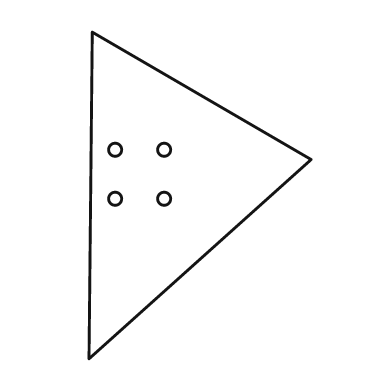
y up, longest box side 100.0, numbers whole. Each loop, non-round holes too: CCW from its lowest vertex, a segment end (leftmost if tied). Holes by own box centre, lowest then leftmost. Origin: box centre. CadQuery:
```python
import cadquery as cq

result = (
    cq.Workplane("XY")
    .moveTo(-34.0, -50.0)
    .lineTo(34.0, 11.0)
    .lineTo(-33.0, 50.0)
    .close()
    .moveTo(-26.0, -1.0)
    .circle(2.0)
    .moveTo(-11.0, -1.0)
    .circle(2.0)
    .moveTo(-26.0, 14.0)
    .circle(2.0)
    .moveTo(-11.0, 14.0)
    .circle(2.0)
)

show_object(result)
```